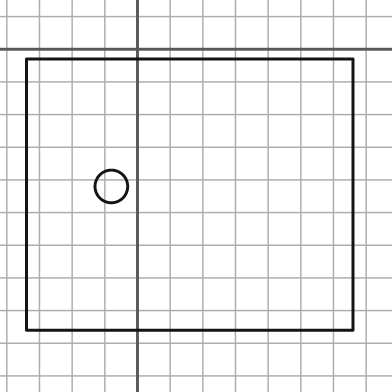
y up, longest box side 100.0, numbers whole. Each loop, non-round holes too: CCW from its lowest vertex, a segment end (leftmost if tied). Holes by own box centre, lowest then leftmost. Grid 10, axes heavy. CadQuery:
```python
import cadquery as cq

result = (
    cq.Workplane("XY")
    .moveTo(-34.0, -86.0)
    .lineTo(66.0, -86.0)
    .lineTo(66.0, -3.0)
    .lineTo(-34.0, -3.0)
    .close()
    .moveTo(-8.0, -42.0)
    .circle(5.0)
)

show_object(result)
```